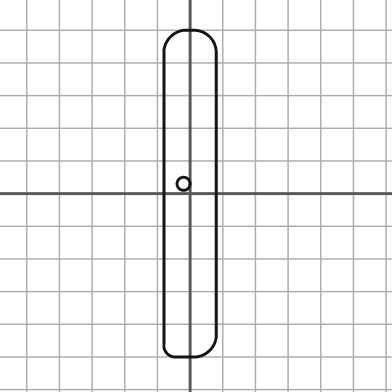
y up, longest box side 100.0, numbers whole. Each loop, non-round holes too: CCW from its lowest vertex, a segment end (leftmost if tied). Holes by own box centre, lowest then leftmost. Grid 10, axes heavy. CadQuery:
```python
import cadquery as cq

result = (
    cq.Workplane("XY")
    .moveTo(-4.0, -50.0)
    .lineTo(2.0, -50.0)
    .threePointArc((6.0, -48.0), (8.0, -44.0))
    .lineTo(8.0, 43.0)
    .threePointArc((6.0, 48.0), (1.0, 50.0))
    .lineTo(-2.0, 50.0)
    .threePointArc((-6.0, 48.0), (-8.0, 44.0))
    .lineTo(-8.0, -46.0)
    .threePointArc((-7.0, -49.0), (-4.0, -50.0))
    .close()
    .moveTo(-2.0, 3.0)
    .circle(2.0)
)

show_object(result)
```